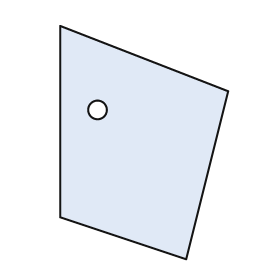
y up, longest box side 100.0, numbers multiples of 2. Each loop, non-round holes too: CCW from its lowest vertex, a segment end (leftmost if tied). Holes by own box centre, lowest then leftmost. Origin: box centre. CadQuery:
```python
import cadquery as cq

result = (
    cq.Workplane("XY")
    .moveTo(18.0, -50.0)
    .lineTo(36.0, 22.0)
    .lineTo(-36.0, 50.0)
    .lineTo(-36.0, -32.0)
    .close()
    .moveTo(-20.0, 14.0)
    .circle(4.0)
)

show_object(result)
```